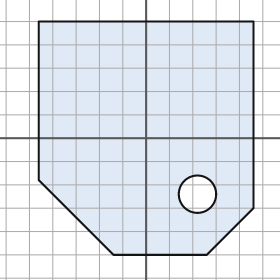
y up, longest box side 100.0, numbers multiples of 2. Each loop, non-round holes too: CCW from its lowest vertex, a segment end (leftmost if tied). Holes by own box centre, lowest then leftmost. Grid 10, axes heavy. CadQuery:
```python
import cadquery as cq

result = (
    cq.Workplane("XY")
    .moveTo(-14.0, -50.0)
    .lineTo(26.0, -50.0)
    .lineTo(46.0, -30.0)
    .lineTo(46.0, 50.0)
    .lineTo(-46.0, 50.0)
    .lineTo(-46.0, -18.0)
    .close()
    .moveTo(22.0, -24.0)
    .circle(8.0)
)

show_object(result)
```